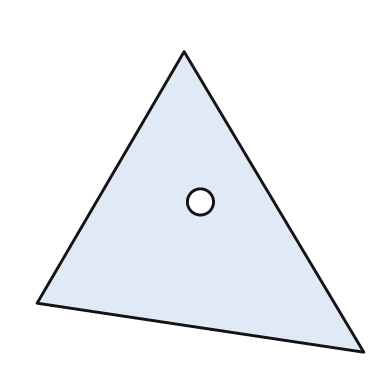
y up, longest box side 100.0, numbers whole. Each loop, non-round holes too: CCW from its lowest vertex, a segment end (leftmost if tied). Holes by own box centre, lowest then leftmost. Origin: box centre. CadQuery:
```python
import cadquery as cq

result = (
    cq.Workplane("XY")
    .moveTo(50.0, -46.0)
    .lineTo(-5.0, 46.0)
    .lineTo(-50.0, -31.0)
    .close()
    .moveTo(0.0, 0.0)
    .circle(4.0)
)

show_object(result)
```